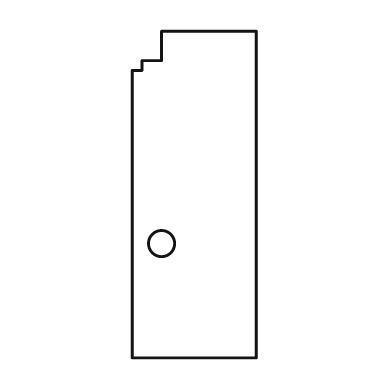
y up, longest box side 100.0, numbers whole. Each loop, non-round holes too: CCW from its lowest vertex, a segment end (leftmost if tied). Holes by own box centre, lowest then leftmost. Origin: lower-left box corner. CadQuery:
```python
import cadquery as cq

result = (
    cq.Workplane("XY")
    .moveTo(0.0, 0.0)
    .lineTo(38.0, 0.0)
    .lineTo(38.0, 100.0)
    .lineTo(9.0, 100.0)
    .lineTo(9.0, 91.0)
    .lineTo(3.0, 91.0)
    .lineTo(3.0, 88.0)
    .lineTo(0.0, 88.0)
    .close()
    .moveTo(9.0, 35.0)
    .circle(4.0)
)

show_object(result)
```